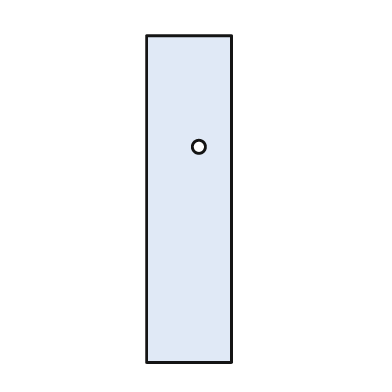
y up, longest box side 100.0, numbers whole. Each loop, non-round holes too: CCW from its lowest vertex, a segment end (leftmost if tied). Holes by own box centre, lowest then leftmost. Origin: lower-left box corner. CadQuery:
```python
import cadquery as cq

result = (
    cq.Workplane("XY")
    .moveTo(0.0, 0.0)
    .lineTo(26.0, 0.0)
    .lineTo(26.0, 100.0)
    .lineTo(0.0, 100.0)
    .close()
    .moveTo(16.0, 66.0)
    .circle(2.0)
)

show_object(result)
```